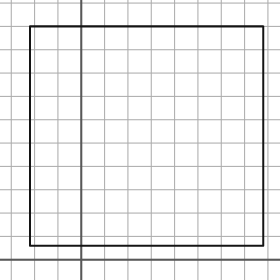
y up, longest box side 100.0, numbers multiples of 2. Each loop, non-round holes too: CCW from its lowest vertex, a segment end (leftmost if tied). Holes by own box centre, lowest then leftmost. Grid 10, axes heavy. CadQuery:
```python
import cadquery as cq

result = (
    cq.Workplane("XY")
    .moveTo(-22.0, 6.0)
    .lineTo(78.0, 6.0)
    .lineTo(78.0, 100.0)
    .lineTo(-22.0, 100.0)
    .close()
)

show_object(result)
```